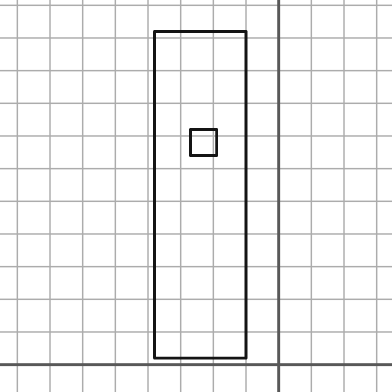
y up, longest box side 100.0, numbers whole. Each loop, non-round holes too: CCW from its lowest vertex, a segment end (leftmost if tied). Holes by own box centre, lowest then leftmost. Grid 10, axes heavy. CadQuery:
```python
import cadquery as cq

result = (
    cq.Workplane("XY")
    .moveTo(-38.0, 2.0)
    .lineTo(-10.0, 2.0)
    .lineTo(-10.0, 102.0)
    .lineTo(-38.0, 102.0)
    .close()
    .moveTo(-27.0, 64.0)
    .lineTo(-19.0, 64.0)
    .lineTo(-19.0, 72.0)
    .lineTo(-27.0, 72.0)
    .close()
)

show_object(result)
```